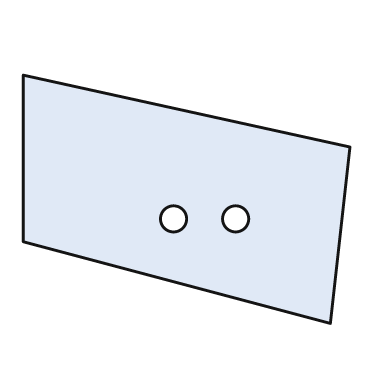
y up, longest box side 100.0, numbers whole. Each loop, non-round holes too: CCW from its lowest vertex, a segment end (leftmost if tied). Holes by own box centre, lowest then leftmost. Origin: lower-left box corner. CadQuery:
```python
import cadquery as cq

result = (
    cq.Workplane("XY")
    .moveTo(94.0, 0.0)
    .lineTo(100.0, 54.0)
    .lineTo(0.0, 76.0)
    .lineTo(0.0, 25.0)
    .close()
    .moveTo(46.0, 32.0)
    .circle(4.0)
    .moveTo(65.0, 32.0)
    .circle(4.0)
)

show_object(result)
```